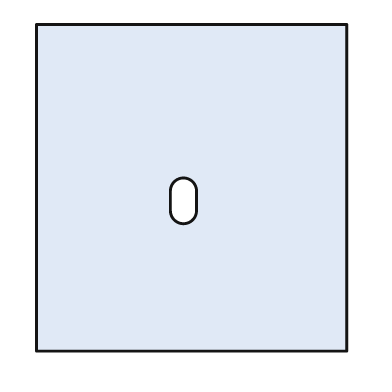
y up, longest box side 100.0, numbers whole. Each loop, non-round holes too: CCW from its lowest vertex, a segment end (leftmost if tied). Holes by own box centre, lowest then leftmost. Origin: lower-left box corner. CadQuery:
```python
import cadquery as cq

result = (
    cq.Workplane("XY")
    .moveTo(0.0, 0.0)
    .lineTo(95.0, 0.0)
    .lineTo(95.0, 100.0)
    .lineTo(0.0, 100.0)
    .close()
    .moveTo(41.0, 43.0)
    .threePointArc((45.0, 39.0), (49.0, 43.0))
    .lineTo(49.0, 49.0)
    .threePointArc((45.0, 53.0), (41.0, 49.0))
    .close()
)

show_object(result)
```